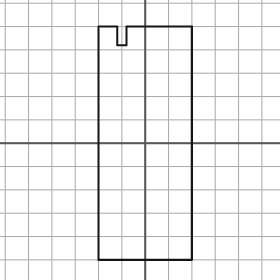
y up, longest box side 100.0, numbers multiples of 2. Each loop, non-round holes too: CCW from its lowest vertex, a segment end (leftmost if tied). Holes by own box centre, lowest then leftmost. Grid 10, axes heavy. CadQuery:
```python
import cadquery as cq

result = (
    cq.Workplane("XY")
    .moveTo(-20.0, -50.0)
    .lineTo(20.0, -50.0)
    .lineTo(20.0, 50.0)
    .lineTo(-8.0, 50.0)
    .lineTo(-8.0, 42.0)
    .lineTo(-12.0, 42.0)
    .lineTo(-12.0, 50.0)
    .lineTo(-20.0, 50.0)
    .close()
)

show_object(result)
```